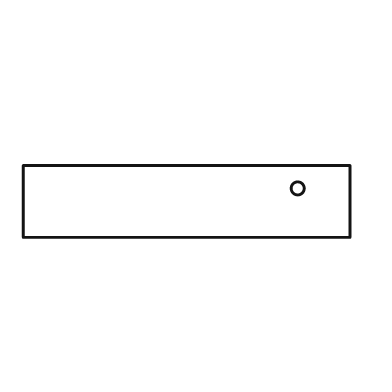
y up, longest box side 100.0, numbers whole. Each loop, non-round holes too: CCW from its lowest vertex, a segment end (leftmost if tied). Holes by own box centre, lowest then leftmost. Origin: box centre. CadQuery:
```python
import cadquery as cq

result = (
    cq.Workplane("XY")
    .moveTo(-50.0, -11.0)
    .lineTo(50.0, -11.0)
    .lineTo(50.0, 11.0)
    .lineTo(-50.0, 11.0)
    .close()
    .moveTo(34.0, 4.0)
    .circle(2.0)
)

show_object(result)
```